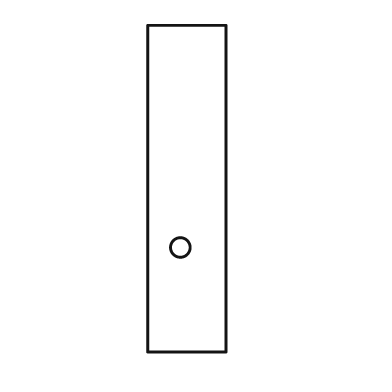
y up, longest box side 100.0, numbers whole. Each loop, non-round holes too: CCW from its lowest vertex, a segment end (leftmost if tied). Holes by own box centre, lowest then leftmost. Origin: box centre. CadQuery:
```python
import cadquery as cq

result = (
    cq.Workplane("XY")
    .moveTo(-12.0, -50.0)
    .lineTo(12.0, -50.0)
    .lineTo(12.0, 50.0)
    .lineTo(-12.0, 50.0)
    .close()
    .moveTo(-2.0, -18.0)
    .circle(3.0)
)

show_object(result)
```